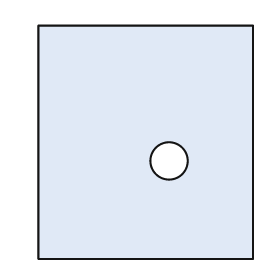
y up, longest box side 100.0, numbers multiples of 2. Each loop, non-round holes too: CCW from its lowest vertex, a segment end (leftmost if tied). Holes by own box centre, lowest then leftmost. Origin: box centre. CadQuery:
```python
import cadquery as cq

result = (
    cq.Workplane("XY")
    .moveTo(-46.0, -50.0)
    .lineTo(46.0, -50.0)
    .lineTo(46.0, 50.0)
    .lineTo(-46.0, 50.0)
    .close()
    .moveTo(10.0, -8.0)
    .circle(8.0)
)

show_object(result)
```